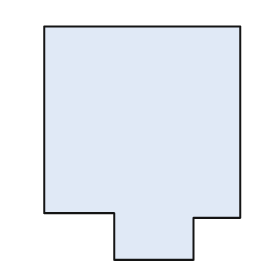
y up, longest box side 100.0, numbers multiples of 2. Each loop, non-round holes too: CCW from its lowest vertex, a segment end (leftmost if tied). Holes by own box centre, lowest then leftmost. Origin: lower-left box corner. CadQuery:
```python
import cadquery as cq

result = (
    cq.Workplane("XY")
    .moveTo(30.0, 0.0)
    .lineTo(64.0, 0.0)
    .lineTo(64.0, 18.0)
    .lineTo(84.0, 18.0)
    .lineTo(84.0, 100.0)
    .lineTo(0.0, 100.0)
    .lineTo(0.0, 20.0)
    .lineTo(30.0, 20.0)
    .close()
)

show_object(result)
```